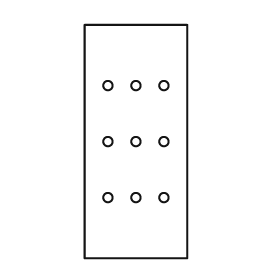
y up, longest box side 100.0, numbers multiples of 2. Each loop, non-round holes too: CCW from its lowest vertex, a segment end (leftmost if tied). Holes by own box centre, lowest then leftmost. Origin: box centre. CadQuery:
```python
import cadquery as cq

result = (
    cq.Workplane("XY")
    .moveTo(-22.0, -50.0)
    .lineTo(22.0, -50.0)
    .lineTo(22.0, 50.0)
    .lineTo(-22.0, 50.0)
    .close()
    .moveTo(-12.0, -24.0)
    .circle(2.0)
    .moveTo(0.0, -24.0)
    .circle(2.0)
    .moveTo(12.0, -24.0)
    .circle(2.0)
    .moveTo(-12.0, 0.0)
    .circle(2.0)
    .moveTo(0.0, 0.0)
    .circle(2.0)
    .moveTo(12.0, 0.0)
    .circle(2.0)
    .moveTo(-12.0, 24.0)
    .circle(2.0)
    .moveTo(0.0, 24.0)
    .circle(2.0)
    .moveTo(12.0, 24.0)
    .circle(2.0)
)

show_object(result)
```